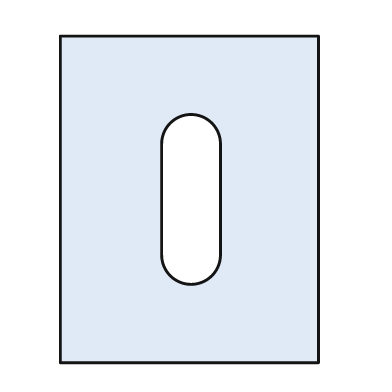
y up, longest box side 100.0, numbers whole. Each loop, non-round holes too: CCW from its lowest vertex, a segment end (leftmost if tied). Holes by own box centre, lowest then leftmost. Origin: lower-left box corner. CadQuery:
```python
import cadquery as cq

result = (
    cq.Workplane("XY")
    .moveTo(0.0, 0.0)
    .lineTo(79.0, 0.0)
    .lineTo(79.0, 100.0)
    .lineTo(0.0, 100.0)
    .close()
    .moveTo(31.0, 33.0)
    .threePointArc((40.0, 24.0), (49.0, 33.0))
    .lineTo(49.0, 67.0)
    .threePointArc((40.0, 76.0), (31.0, 67.0))
    .close()
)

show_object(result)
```